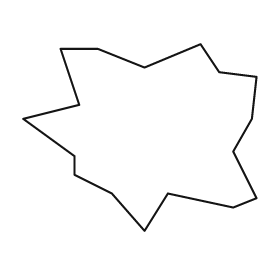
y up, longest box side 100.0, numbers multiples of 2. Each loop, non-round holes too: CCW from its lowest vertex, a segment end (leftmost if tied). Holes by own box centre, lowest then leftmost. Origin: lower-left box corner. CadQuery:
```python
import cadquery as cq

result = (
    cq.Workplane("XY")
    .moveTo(52.0, 0.0)
    .lineTo(62.0, 16.0)
    .lineTo(90.0, 10.0)
    .lineTo(100.0, 14.0)
    .lineTo(90.0, 34.0)
    .lineTo(98.0, 48.0)
    .lineTo(100.0, 66.0)
    .lineTo(84.0, 68.0)
    .lineTo(76.0, 80.0)
    .lineTo(52.0, 70.0)
    .lineTo(32.0, 78.0)
    .lineTo(16.0, 78.0)
    .lineTo(24.0, 54.0)
    .lineTo(0.0, 48.0)
    .lineTo(22.0, 32.0)
    .lineTo(22.0, 24.0)
    .lineTo(38.0, 16.0)
    .close()
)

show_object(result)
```